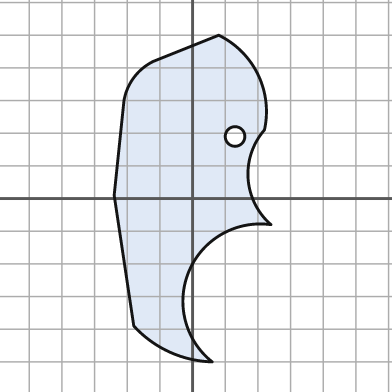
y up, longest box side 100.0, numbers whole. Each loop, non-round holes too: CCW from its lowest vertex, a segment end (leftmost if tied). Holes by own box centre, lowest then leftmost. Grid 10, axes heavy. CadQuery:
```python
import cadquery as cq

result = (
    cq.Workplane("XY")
    .moveTo(6.0, -50.0)
    .threePointArc((-1.0, -22.0), (24.0, -8.0))
    .threePointArc((17.0, 6.0), (22.0, 21.0))
    .threePointArc((20.0, 38.0), (8.0, 50.0))
    .lineTo(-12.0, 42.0)
    .threePointArc((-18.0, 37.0), (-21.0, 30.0))
    .lineTo(-24.0, 1.0)
    .lineTo(-18.0, -39.0)
    .threePointArc((-7.0, -47.0), (6.0, -50.0))
    .close()
    .moveTo(13.0, 19.0)
    .circle(3.0)
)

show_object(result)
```